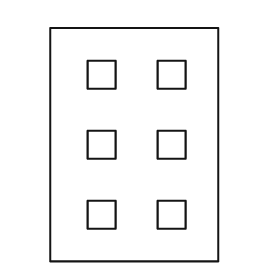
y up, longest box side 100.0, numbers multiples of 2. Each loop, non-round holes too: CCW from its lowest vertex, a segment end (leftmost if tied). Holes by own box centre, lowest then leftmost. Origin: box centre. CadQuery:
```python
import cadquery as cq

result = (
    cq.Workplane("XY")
    .moveTo(-36.0, -50.0)
    .lineTo(36.0, -50.0)
    .lineTo(36.0, 50.0)
    .lineTo(-36.0, 50.0)
    .close()
    .moveTo(-20.0, -36.0)
    .lineTo(-8.0, -36.0)
    .lineTo(-8.0, -24.0)
    .lineTo(-20.0, -24.0)
    .close()
    .moveTo(10.0, -36.0)
    .lineTo(22.0, -36.0)
    .lineTo(22.0, -24.0)
    .lineTo(10.0, -24.0)
    .close()
    .moveTo(-20.0, -6.0)
    .lineTo(-8.0, -6.0)
    .lineTo(-8.0, 6.0)
    .lineTo(-20.0, 6.0)
    .close()
    .moveTo(10.0, -6.0)
    .lineTo(22.0, -6.0)
    .lineTo(22.0, 6.0)
    .lineTo(10.0, 6.0)
    .close()
    .moveTo(-20.0, 24.0)
    .lineTo(-8.0, 24.0)
    .lineTo(-8.0, 36.0)
    .lineTo(-20.0, 36.0)
    .close()
    .moveTo(10.0, 24.0)
    .lineTo(22.0, 24.0)
    .lineTo(22.0, 36.0)
    .lineTo(10.0, 36.0)
    .close()
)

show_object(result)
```